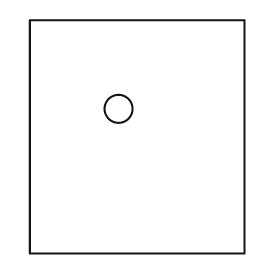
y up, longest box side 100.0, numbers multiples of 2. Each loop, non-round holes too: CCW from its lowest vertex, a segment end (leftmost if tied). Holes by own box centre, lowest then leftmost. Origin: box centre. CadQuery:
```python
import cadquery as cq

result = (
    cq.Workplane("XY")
    .moveTo(-46.0, -50.0)
    .lineTo(46.0, -50.0)
    .lineTo(46.0, 50.0)
    .lineTo(-46.0, 50.0)
    .close()
    .moveTo(-8.0, 12.0)
    .circle(6.0)
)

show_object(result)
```